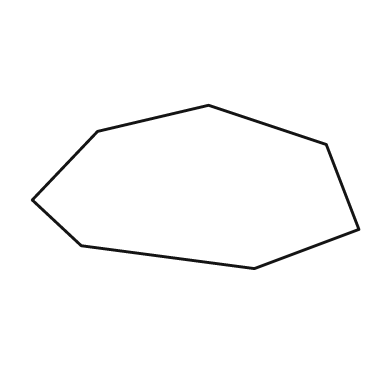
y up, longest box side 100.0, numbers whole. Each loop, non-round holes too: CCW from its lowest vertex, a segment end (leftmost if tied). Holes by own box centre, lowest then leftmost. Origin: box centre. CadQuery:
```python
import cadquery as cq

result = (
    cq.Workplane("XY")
    .moveTo(18.0, -25.0)
    .lineTo(50.0, -13.0)
    .lineTo(40.0, 13.0)
    .lineTo(4.0, 25.0)
    .lineTo(-30.0, 17.0)
    .lineTo(-50.0, -4.0)
    .lineTo(-35.0, -18.0)
    .close()
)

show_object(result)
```